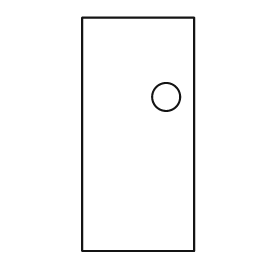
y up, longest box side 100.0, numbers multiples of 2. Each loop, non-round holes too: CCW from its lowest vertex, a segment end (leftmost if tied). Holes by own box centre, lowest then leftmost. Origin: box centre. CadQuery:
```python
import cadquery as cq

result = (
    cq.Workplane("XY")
    .moveTo(-24.0, -50.0)
    .lineTo(24.0, -50.0)
    .lineTo(24.0, 50.0)
    .lineTo(-24.0, 50.0)
    .close()
    .moveTo(12.0, 16.0)
    .circle(6.0)
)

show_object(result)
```